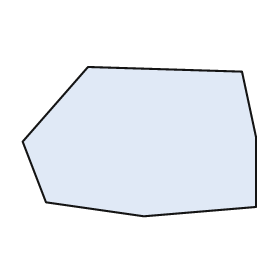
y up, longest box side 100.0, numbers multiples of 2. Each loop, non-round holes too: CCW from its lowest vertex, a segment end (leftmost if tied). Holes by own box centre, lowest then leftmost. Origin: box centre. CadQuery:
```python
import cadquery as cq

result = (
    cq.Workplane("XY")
    .moveTo(2.0, -32.0)
    .lineTo(50.0, -28.0)
    .lineTo(50.0, 2.0)
    .lineTo(44.0, 30.0)
    .lineTo(-22.0, 32.0)
    .lineTo(-50.0, 0.0)
    .lineTo(-40.0, -26.0)
    .close()
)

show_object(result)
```